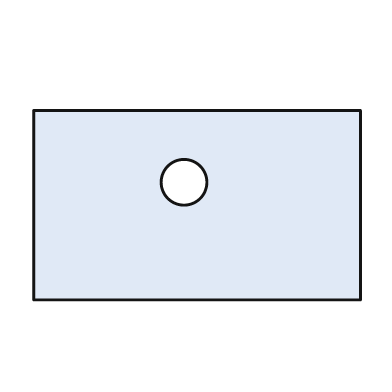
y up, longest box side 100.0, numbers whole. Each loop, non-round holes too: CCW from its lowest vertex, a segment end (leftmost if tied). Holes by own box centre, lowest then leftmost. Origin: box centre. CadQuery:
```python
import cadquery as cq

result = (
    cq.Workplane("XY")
    .moveTo(-50.0, -29.0)
    .lineTo(50.0, -29.0)
    .lineTo(50.0, 29.0)
    .lineTo(-50.0, 29.0)
    .close()
    .moveTo(-4.0, 7.0)
    .circle(7.0)
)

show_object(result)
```